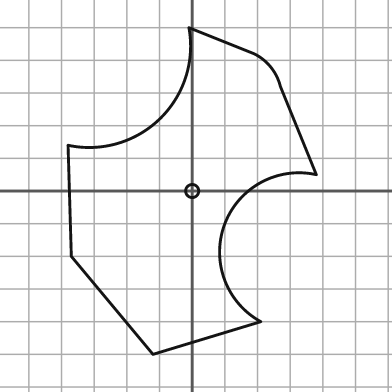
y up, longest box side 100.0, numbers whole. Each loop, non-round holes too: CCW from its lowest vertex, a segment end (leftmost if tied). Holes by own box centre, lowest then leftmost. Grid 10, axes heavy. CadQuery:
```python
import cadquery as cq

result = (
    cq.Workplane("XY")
    .moveTo(-12.0, -50.0)
    .lineTo(21.0, -40.0)
    .threePointArc((10.0, -10.0), (38.0, 5.0))
    .lineTo(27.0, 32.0)
    .threePointArc((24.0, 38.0), (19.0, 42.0))
    .lineTo(-1.0, 50.0)
    .threePointArc((-10.0, 22.0), (-38.0, 14.0))
    .lineTo(-37.0, -20.0)
    .close()
    .moveTo(0.0, 0.0)
    .circle(2.0)
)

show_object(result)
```